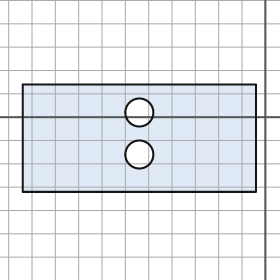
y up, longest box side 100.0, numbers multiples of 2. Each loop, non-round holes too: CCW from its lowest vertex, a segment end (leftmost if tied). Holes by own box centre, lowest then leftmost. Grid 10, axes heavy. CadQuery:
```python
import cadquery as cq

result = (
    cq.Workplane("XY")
    .moveTo(-104.0, -32.0)
    .lineTo(-4.0, -32.0)
    .lineTo(-4.0, 14.0)
    .lineTo(-104.0, 14.0)
    .close()
    .moveTo(-54.0, -16.0)
    .circle(6.0)
    .moveTo(-54.0, 2.0)
    .circle(6.0)
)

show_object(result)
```